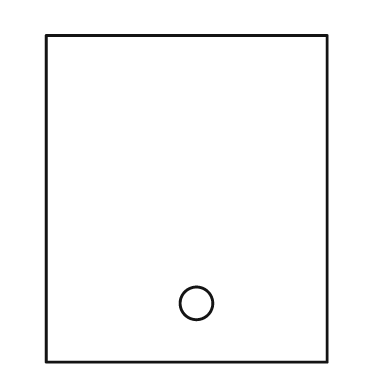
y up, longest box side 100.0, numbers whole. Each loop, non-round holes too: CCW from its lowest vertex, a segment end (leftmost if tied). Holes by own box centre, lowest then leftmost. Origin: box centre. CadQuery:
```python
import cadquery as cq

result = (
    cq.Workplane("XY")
    .moveTo(-43.0, -50.0)
    .lineTo(43.0, -50.0)
    .lineTo(43.0, 50.0)
    .lineTo(-43.0, 50.0)
    .close()
    .moveTo(3.0, -32.0)
    .circle(5.0)
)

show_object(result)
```